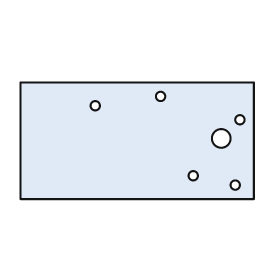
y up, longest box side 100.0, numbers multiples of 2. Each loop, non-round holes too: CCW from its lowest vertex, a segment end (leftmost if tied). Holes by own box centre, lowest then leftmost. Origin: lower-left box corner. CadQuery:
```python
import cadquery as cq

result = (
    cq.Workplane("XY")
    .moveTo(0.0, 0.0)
    .lineTo(100.0, 0.0)
    .lineTo(100.0, 50.0)
    .lineTo(0.0, 50.0)
    .close()
    .moveTo(92.0, 6.0)
    .circle(2.0)
    .moveTo(74.0, 10.0)
    .circle(2.0)
    .moveTo(86.0, 26.0)
    .circle(4.0)
    .moveTo(94.0, 34.0)
    .circle(2.0)
    .moveTo(32.0, 40.0)
    .circle(2.0)
    .moveTo(60.0, 44.0)
    .circle(2.0)
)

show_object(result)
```